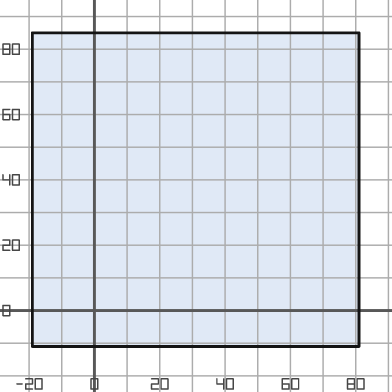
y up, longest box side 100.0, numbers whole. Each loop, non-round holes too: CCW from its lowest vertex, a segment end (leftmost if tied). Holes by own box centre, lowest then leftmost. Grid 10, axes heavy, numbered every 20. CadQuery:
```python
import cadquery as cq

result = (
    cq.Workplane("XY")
    .moveTo(-19.0, -11.0)
    .lineTo(81.0, -11.0)
    .lineTo(81.0, 85.0)
    .lineTo(-19.0, 85.0)
    .close()
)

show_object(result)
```